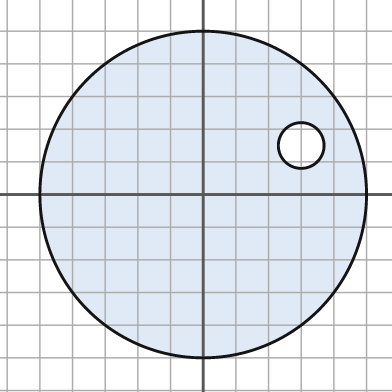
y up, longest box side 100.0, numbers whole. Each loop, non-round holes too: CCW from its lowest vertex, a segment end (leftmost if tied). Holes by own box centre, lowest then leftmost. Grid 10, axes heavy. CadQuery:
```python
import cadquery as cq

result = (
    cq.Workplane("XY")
    .moveTo(0.0, 0.0)
    .circle(50.0)
    .moveTo(30.0, 15.0)
    .circle(7.0)
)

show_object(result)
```